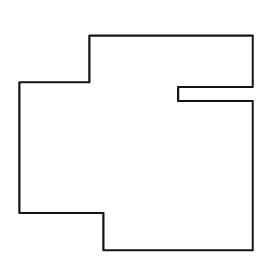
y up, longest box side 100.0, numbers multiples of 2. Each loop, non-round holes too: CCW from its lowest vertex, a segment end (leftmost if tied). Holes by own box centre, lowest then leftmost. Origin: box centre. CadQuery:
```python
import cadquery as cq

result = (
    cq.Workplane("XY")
    .moveTo(-14.0, -46.0)
    .lineTo(50.0, -46.0)
    .lineTo(50.0, 18.0)
    .lineTo(18.0, 18.0)
    .lineTo(18.0, 24.0)
    .lineTo(50.0, 24.0)
    .lineTo(50.0, 46.0)
    .lineTo(-20.0, 46.0)
    .lineTo(-20.0, 26.0)
    .lineTo(-50.0, 26.0)
    .lineTo(-50.0, -30.0)
    .lineTo(-14.0, -30.0)
    .close()
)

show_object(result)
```